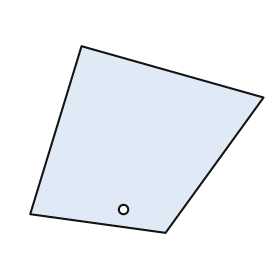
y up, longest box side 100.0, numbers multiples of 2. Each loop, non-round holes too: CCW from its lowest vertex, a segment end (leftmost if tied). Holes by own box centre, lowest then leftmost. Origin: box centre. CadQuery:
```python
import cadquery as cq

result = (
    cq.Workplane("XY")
    .moveTo(8.0, -40.0)
    .lineTo(50.0, 18.0)
    .lineTo(-28.0, 40.0)
    .lineTo(-50.0, -32.0)
    .close()
    .moveTo(-10.0, -30.0)
    .circle(2.0)
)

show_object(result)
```